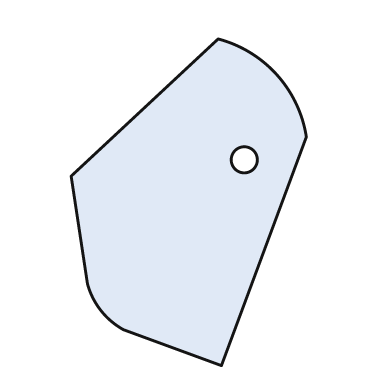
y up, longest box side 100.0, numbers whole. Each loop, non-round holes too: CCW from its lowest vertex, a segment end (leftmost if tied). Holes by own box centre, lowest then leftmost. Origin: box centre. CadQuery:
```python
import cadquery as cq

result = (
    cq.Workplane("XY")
    .moveTo(10.0, -50.0)
    .lineTo(36.0, 20.0)
    .threePointArc((27.0, 39.0), (9.0, 50.0))
    .lineTo(-36.0, 8.0)
    .lineTo(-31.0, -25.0)
    .threePointArc((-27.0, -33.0), (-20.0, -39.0))
    .close()
    .moveTo(17.0, 13.0)
    .circle(4.0)
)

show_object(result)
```